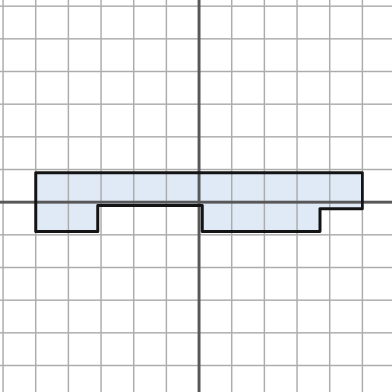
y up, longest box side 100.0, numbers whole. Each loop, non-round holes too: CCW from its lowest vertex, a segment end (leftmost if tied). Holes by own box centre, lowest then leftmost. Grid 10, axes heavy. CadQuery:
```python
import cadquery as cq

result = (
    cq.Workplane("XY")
    .moveTo(-50.0, -9.0)
    .lineTo(-31.0, -9.0)
    .lineTo(-31.0, -1.0)
    .lineTo(1.0, -1.0)
    .lineTo(1.0, -9.0)
    .lineTo(37.0, -9.0)
    .lineTo(37.0, -2.0)
    .lineTo(50.0, -2.0)
    .lineTo(50.0, 9.0)
    .lineTo(-50.0, 9.0)
    .close()
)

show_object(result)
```